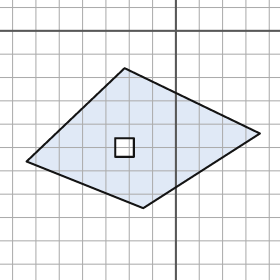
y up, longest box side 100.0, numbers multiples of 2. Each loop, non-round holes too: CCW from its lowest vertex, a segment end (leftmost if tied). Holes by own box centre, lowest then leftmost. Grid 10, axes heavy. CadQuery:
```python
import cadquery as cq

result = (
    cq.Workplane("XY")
    .moveTo(-14.0, -76.0)
    .lineTo(36.0, -44.0)
    .lineTo(-22.0, -16.0)
    .lineTo(-64.0, -56.0)
    .close()
    .moveTo(-26.0, -54.0)
    .lineTo(-18.0, -54.0)
    .lineTo(-18.0, -46.0)
    .lineTo(-26.0, -46.0)
    .close()
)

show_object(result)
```